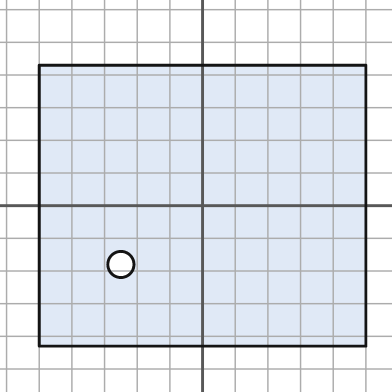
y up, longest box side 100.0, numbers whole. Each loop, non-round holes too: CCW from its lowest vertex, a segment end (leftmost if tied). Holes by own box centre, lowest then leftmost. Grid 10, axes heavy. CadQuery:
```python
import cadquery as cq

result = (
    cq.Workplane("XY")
    .moveTo(-50.0, -43.0)
    .lineTo(50.0, -43.0)
    .lineTo(50.0, 43.0)
    .lineTo(-50.0, 43.0)
    .close()
    .moveTo(-25.0, -18.0)
    .circle(4.0)
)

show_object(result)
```